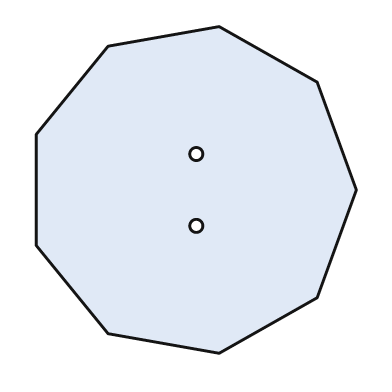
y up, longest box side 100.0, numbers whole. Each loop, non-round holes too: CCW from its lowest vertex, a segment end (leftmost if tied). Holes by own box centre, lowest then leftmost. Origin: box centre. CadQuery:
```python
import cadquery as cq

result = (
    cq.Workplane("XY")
    .moveTo(7.0, -50.0)
    .lineTo(37.0, -33.0)
    .lineTo(49.0, 0.0)
    .lineTo(37.0, 33.0)
    .lineTo(7.0, 50.0)
    .lineTo(-27.0, 44.0)
    .lineTo(-49.0, 17.0)
    .lineTo(-49.0, -17.0)
    .lineTo(-27.0, -44.0)
    .close()
    .moveTo(0.0, -11.0)
    .circle(2.0)
    .moveTo(0.0, 11.0)
    .circle(2.0)
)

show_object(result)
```